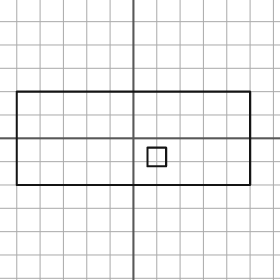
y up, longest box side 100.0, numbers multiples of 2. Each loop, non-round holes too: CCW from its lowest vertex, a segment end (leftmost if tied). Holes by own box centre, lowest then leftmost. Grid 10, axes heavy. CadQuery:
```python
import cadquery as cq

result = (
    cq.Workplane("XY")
    .moveTo(-50.0, -20.0)
    .lineTo(50.0, -20.0)
    .lineTo(50.0, 20.0)
    .lineTo(-50.0, 20.0)
    .close()
    .moveTo(6.0, -12.0)
    .lineTo(14.0, -12.0)
    .lineTo(14.0, -4.0)
    .lineTo(6.0, -4.0)
    .close()
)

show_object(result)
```